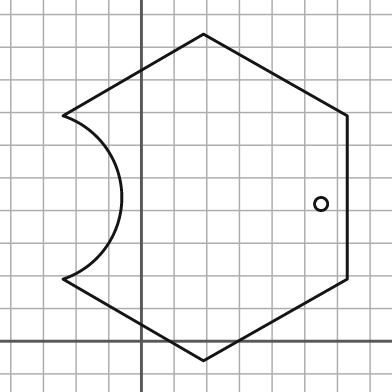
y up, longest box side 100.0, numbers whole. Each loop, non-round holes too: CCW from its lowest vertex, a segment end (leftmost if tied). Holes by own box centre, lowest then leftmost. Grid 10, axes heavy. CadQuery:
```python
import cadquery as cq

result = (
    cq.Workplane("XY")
    .moveTo(19.0, -6.0)
    .lineTo(63.0, 19.0)
    .lineTo(63.0, 69.0)
    .lineTo(19.0, 94.0)
    .lineTo(-24.0, 69.0)
    .threePointArc((-6.0, 44.0), (-24.0, 19.0))
    .close()
    .moveTo(55.0, 42.0)
    .circle(2.0)
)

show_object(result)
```